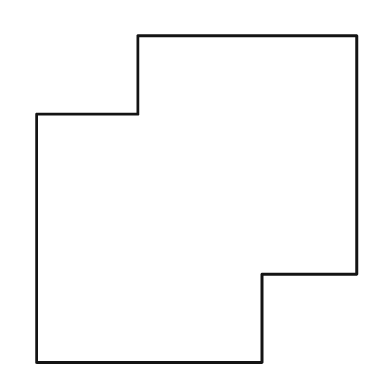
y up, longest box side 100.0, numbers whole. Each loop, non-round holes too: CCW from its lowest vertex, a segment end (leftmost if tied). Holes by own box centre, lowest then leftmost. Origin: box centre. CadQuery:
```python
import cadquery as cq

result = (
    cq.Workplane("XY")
    .moveTo(-49.0, -50.0)
    .lineTo(20.0, -50.0)
    .lineTo(20.0, -23.0)
    .lineTo(49.0, -23.0)
    .lineTo(49.0, 50.0)
    .lineTo(-18.0, 50.0)
    .lineTo(-18.0, 26.0)
    .lineTo(-49.0, 26.0)
    .close()
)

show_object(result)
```